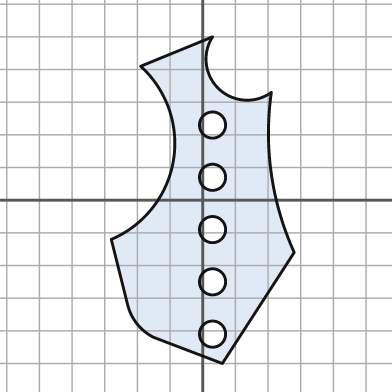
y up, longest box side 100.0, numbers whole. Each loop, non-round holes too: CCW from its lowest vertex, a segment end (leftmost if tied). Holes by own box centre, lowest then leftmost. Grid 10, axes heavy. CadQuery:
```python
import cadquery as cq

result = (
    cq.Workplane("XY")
    .moveTo(6.0, -50.0)
    .lineTo(28.0, -16.0)
    .threePointArc((21.0, 8.0), (21.0, 33.0))
    .threePointArc((5.0, 34.0), (3.0, 50.0))
    .lineTo(-19.0, 41.0)
    .threePointArc((-9.0, 12.0), (-28.0, -12.0))
    .lineTo(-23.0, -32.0)
    .threePointArc((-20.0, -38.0), (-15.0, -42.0))
    .close()
    .moveTo(3.0, -41.0)
    .circle(4.0)
    .moveTo(3.0, -25.0)
    .circle(4.0)
    .moveTo(3.0, -9.0)
    .circle(4.0)
    .moveTo(3.0, 7.0)
    .circle(4.0)
    .moveTo(3.0, 23.0)
    .circle(4.0)
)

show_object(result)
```